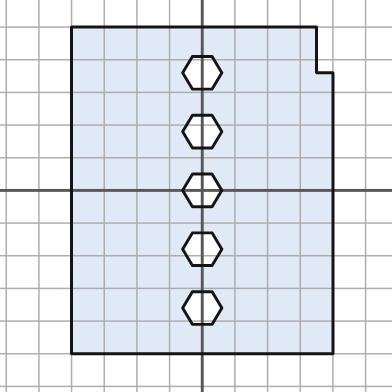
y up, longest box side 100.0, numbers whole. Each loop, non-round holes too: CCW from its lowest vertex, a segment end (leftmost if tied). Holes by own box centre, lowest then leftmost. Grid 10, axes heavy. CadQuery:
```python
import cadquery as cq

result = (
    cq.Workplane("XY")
    .moveTo(-40.0, -50.0)
    .lineTo(40.0, -50.0)
    .lineTo(40.0, 36.0)
    .lineTo(35.0, 36.0)
    .lineTo(35.0, 50.0)
    .lineTo(-40.0, 50.0)
    .close()
    .moveTo(-3.0, -41.0)
    .lineTo(3.0, -41.0)
    .lineTo(6.0, -36.0)
    .lineTo(3.0, -31.0)
    .lineTo(-3.0, -31.0)
    .lineTo(-6.0, -36.0)
    .close()
    .moveTo(-3.0, -23.0)
    .lineTo(3.0, -23.0)
    .lineTo(6.0, -18.0)
    .lineTo(3.0, -13.0)
    .lineTo(-3.0, -13.0)
    .lineTo(-6.0, -18.0)
    .close()
    .moveTo(-3.0, -5.0)
    .lineTo(3.0, -5.0)
    .lineTo(6.0, 0.0)
    .lineTo(3.0, 5.0)
    .lineTo(-3.0, 5.0)
    .lineTo(-6.0, 0.0)
    .close()
    .moveTo(-3.0, 13.0)
    .lineTo(3.0, 13.0)
    .lineTo(6.0, 18.0)
    .lineTo(3.0, 23.0)
    .lineTo(-3.0, 23.0)
    .lineTo(-6.0, 18.0)
    .close()
    .moveTo(-3.0, 31.0)
    .lineTo(3.0, 31.0)
    .lineTo(6.0, 36.0)
    .lineTo(3.0, 41.0)
    .lineTo(-3.0, 41.0)
    .lineTo(-6.0, 36.0)
    .close()
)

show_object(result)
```